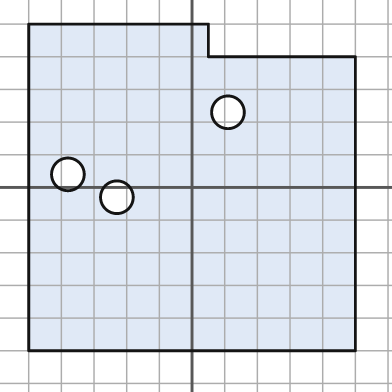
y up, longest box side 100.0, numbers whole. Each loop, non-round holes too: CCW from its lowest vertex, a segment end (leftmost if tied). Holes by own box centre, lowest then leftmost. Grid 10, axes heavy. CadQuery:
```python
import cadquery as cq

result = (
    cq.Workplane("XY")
    .moveTo(-50.0, -50.0)
    .lineTo(50.0, -50.0)
    .lineTo(50.0, 40.0)
    .lineTo(5.0, 40.0)
    .lineTo(5.0, 50.0)
    .lineTo(-50.0, 50.0)
    .close()
    .moveTo(-23.0, -3.0)
    .circle(5.0)
    .moveTo(-38.0, 4.0)
    .circle(5.0)
    .moveTo(11.0, 23.0)
    .circle(5.0)
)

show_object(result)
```